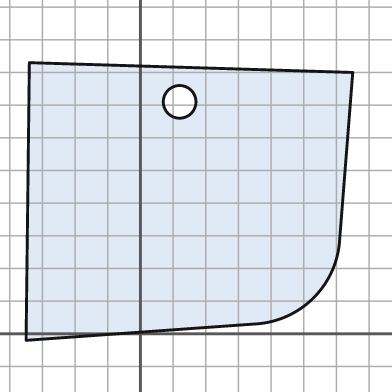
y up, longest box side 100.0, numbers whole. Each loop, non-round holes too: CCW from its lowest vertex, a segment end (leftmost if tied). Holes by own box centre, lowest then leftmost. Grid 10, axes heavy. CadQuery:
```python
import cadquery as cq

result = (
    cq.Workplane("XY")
    .moveTo(-35.0, -2.0)
    .lineTo(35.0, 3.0)
    .threePointArc((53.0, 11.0), (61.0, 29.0))
    .lineTo(65.0, 80.0)
    .lineTo(-34.0, 83.0)
    .close()
    .moveTo(12.0, 71.0)
    .circle(5.0)
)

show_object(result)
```